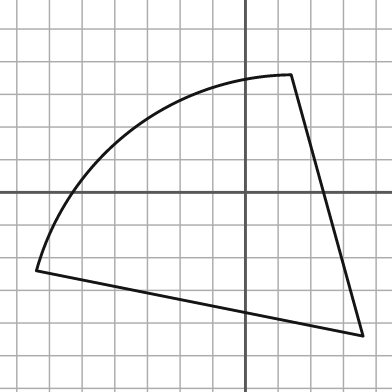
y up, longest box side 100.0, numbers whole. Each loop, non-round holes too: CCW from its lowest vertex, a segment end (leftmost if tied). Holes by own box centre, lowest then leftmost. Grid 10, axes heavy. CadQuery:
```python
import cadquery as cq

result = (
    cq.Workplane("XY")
    .moveTo(36.0, -44.0)
    .lineTo(14.0, 36.0)
    .threePointArc((-35.0, 19.0), (-64.0, -24.0))
    .close()
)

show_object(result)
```